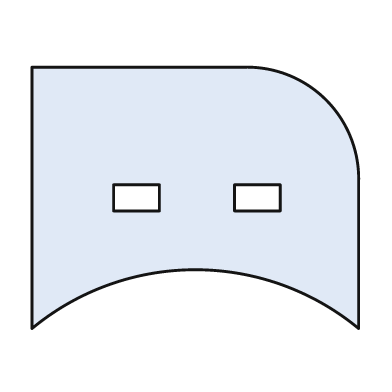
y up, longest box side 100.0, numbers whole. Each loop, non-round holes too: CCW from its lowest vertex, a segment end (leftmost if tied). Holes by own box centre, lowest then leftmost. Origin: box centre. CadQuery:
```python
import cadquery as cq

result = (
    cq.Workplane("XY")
    .moveTo(-50.0, -40.0)
    .threePointArc((0.0, -22.0), (50.0, -40.0))
    .lineTo(50.0, 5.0)
    .threePointArc((40.0, 30.0), (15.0, 40.0))
    .lineTo(-50.0, 40.0)
    .close()
    .moveTo(-25.0, -4.0)
    .lineTo(-11.0, -4.0)
    .lineTo(-11.0, 4.0)
    .lineTo(-25.0, 4.0)
    .close()
    .moveTo(12.0, -4.0)
    .lineTo(26.0, -4.0)
    .lineTo(26.0, 4.0)
    .lineTo(12.0, 4.0)
    .close()
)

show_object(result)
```